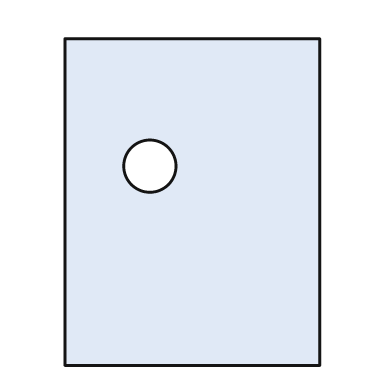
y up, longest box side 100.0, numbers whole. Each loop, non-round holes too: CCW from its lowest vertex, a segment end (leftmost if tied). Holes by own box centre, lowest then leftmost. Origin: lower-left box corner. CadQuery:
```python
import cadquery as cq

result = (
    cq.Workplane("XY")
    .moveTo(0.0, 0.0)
    .lineTo(78.0, 0.0)
    .lineTo(78.0, 100.0)
    .lineTo(0.0, 100.0)
    .close()
    .moveTo(26.0, 61.0)
    .circle(8.0)
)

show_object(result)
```